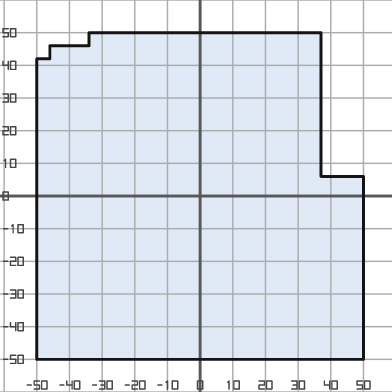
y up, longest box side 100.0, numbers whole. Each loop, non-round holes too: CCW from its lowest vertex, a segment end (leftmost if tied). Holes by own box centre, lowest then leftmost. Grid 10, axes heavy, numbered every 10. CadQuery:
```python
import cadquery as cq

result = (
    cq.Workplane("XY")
    .moveTo(-50.0, -50.0)
    .lineTo(50.0, -50.0)
    .lineTo(50.0, 6.0)
    .lineTo(37.0, 6.0)
    .lineTo(37.0, 50.0)
    .lineTo(-34.0, 50.0)
    .lineTo(-34.0, 46.0)
    .lineTo(-46.0, 46.0)
    .lineTo(-46.0, 42.0)
    .lineTo(-50.0, 42.0)
    .close()
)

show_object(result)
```